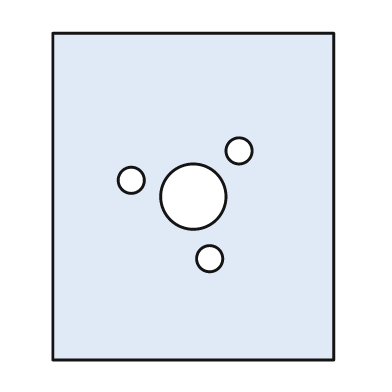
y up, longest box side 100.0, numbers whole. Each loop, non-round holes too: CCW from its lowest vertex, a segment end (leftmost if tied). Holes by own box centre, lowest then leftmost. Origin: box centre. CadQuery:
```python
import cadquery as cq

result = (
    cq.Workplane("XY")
    .moveTo(-43.0, -50.0)
    .lineTo(43.0, -50.0)
    .lineTo(43.0, 50.0)
    .lineTo(-43.0, 50.0)
    .close()
    .moveTo(5.0, -19.0)
    .circle(4.0)
    .moveTo(0.0, 0.0)
    .circle(10.0)
    .moveTo(-19.0, 5.0)
    .circle(4.0)
    .moveTo(14.0, 14.0)
    .circle(4.0)
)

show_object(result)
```